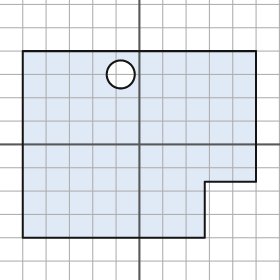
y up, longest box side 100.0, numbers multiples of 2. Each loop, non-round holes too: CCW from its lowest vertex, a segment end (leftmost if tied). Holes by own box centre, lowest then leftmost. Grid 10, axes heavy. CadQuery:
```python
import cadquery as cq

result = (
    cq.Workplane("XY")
    .moveTo(-50.0, -40.0)
    .lineTo(28.0, -40.0)
    .lineTo(28.0, -16.0)
    .lineTo(50.0, -16.0)
    .lineTo(50.0, 40.0)
    .lineTo(-50.0, 40.0)
    .close()
    .moveTo(-8.0, 30.0)
    .circle(6.0)
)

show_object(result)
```